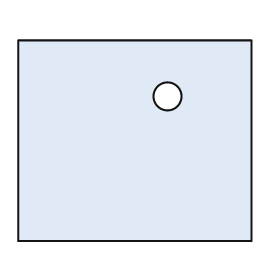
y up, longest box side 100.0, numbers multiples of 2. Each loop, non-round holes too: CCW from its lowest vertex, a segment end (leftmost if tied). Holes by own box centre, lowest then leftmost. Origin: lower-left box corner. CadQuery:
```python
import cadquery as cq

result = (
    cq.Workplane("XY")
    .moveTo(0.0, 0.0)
    .lineTo(100.0, 0.0)
    .lineTo(100.0, 86.0)
    .lineTo(0.0, 86.0)
    .close()
    .moveTo(64.0, 62.0)
    .circle(6.0)
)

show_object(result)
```